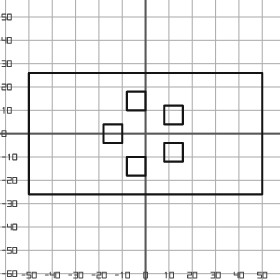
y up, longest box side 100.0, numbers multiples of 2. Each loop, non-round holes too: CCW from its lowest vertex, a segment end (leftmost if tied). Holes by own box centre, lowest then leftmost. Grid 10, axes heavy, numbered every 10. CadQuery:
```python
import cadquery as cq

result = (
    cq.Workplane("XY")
    .moveTo(-50.0, -26.0)
    .lineTo(50.0, -26.0)
    .lineTo(50.0, 26.0)
    .lineTo(-50.0, 26.0)
    .close()
    .moveTo(-8.0, -18.0)
    .lineTo(0.0, -18.0)
    .lineTo(0.0, -10.0)
    .lineTo(-8.0, -10.0)
    .close()
    .moveTo(8.0, -12.0)
    .lineTo(16.0, -12.0)
    .lineTo(16.0, -4.0)
    .lineTo(8.0, -4.0)
    .close()
    .moveTo(-18.0, -4.0)
    .lineTo(-10.0, -4.0)
    .lineTo(-10.0, 4.0)
    .lineTo(-18.0, 4.0)
    .close()
    .moveTo(8.0, 4.0)
    .lineTo(16.0, 4.0)
    .lineTo(16.0, 12.0)
    .lineTo(8.0, 12.0)
    .close()
    .moveTo(-8.0, 10.0)
    .lineTo(0.0, 10.0)
    .lineTo(0.0, 18.0)
    .lineTo(-8.0, 18.0)
    .close()
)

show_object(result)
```